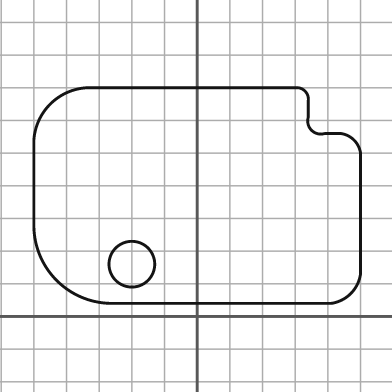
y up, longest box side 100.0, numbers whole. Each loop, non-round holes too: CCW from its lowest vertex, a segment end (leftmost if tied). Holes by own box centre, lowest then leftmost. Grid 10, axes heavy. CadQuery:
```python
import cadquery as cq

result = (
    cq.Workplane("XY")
    .moveTo(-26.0, 4.0)
    .lineTo(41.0, 4.0)
    .threePointArc((47.0, 7.0), (50.0, 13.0))
    .lineTo(50.0, 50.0)
    .threePointArc((48.0, 54.0), (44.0, 56.0))
    .lineTo(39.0, 56.0)
    .threePointArc((35.0, 57.0), (34.0, 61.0))
    .lineTo(34.0, 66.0)
    .threePointArc((33.0, 69.0), (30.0, 70.0))
    .lineTo(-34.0, 70.0)
    .threePointArc((-45.0, 65.0), (-50.0, 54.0))
    .lineTo(-50.0, 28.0)
    .threePointArc((-43.0, 11.0), (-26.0, 4.0))
    .close()
    .moveTo(-20.0, 16.0)
    .circle(7.0)
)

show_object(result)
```